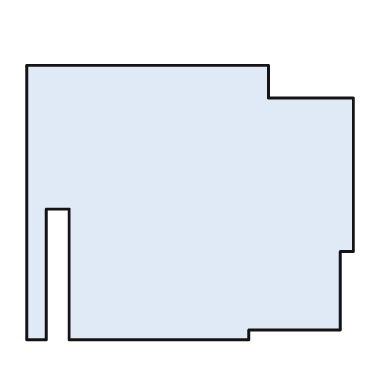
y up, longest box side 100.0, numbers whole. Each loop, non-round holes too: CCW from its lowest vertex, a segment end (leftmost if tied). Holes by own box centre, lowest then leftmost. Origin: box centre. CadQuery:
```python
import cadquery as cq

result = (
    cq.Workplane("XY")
    .moveTo(-50.0, -42.0)
    .lineTo(-44.0, -42.0)
    .lineTo(-44.0, -2.0)
    .lineTo(-37.0, -2.0)
    .lineTo(-37.0, -42.0)
    .lineTo(18.0, -42.0)
    .lineTo(18.0, -39.0)
    .lineTo(46.0, -39.0)
    .lineTo(46.0, -15.0)
    .lineTo(50.0, -15.0)
    .lineTo(50.0, 32.0)
    .lineTo(24.0, 32.0)
    .lineTo(24.0, 42.0)
    .lineTo(-50.0, 42.0)
    .close()
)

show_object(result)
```